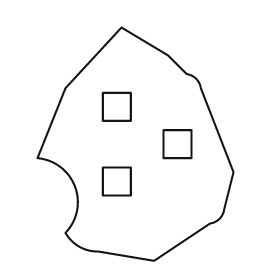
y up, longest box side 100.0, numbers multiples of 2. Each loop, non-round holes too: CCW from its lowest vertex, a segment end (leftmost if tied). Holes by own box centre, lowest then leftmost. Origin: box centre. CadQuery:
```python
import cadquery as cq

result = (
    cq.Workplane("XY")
    .moveTo(8.0, -50.0)
    .lineTo(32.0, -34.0)
    .threePointArc((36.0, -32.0), (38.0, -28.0))
    .lineTo(42.0, -12.0)
    .lineTo(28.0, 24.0)
    .threePointArc((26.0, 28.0), (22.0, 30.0))
    .lineTo(14.0, 38.0)
    .lineTo(-6.0, 50.0)
    .lineTo(-30.0, 24.0)
    .lineTo(-42.0, -6.0)
    .threePointArc((-26.0, -18.0), (-30.0, -38.0))
    .threePointArc((-24.0, -44.0), (-16.0, -46.0))
    .close()
    .moveTo(-14.0, -22.0)
    .lineTo(-2.0, -22.0)
    .lineTo(-2.0, -10.0)
    .lineTo(-14.0, -10.0)
    .close()
    .moveTo(12.0, -6.0)
    .lineTo(24.0, -6.0)
    .lineTo(24.0, 6.0)
    .lineTo(12.0, 6.0)
    .close()
    .moveTo(-14.0, 10.0)
    .lineTo(-2.0, 10.0)
    .lineTo(-2.0, 22.0)
    .lineTo(-14.0, 22.0)
    .close()
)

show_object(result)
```